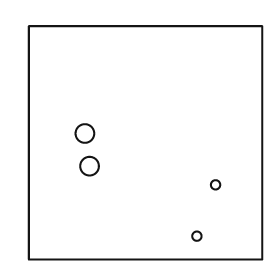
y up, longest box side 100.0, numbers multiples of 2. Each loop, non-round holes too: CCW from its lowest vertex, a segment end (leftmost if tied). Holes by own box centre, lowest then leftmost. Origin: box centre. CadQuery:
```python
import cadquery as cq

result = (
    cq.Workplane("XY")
    .moveTo(-50.0, -50.0)
    .lineTo(50.0, -50.0)
    .lineTo(50.0, 50.0)
    .lineTo(-50.0, 50.0)
    .close()
    .moveTo(22.0, -40.0)
    .circle(2.0)
    .moveTo(30.0, -18.0)
    .circle(2.0)
    .moveTo(-24.0, -10.0)
    .circle(4.0)
    .moveTo(-26.0, 4.0)
    .circle(4.0)
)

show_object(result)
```